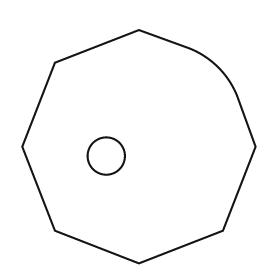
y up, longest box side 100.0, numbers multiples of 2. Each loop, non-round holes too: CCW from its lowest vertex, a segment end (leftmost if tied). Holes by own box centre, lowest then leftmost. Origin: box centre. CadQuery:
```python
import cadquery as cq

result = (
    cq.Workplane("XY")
    .moveTo(0.0, -50.0)
    .lineTo(36.0, -36.0)
    .lineTo(50.0, 0.0)
    .lineTo(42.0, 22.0)
    .threePointArc((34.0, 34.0), (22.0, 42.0))
    .lineTo(0.0, 50.0)
    .lineTo(-36.0, 36.0)
    .lineTo(-50.0, 0.0)
    .lineTo(-36.0, -36.0)
    .close()
    .moveTo(-14.0, -4.0)
    .circle(8.0)
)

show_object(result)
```